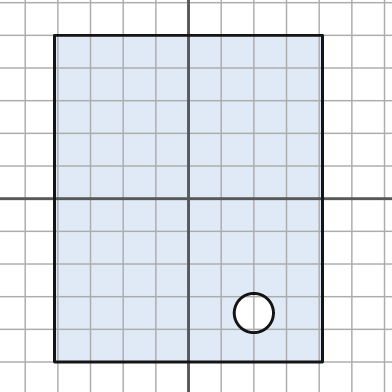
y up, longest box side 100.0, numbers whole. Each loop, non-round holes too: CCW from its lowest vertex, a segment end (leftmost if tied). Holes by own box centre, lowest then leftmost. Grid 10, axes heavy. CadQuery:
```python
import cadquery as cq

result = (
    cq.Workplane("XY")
    .moveTo(-41.0, -50.0)
    .lineTo(41.0, -50.0)
    .lineTo(41.0, 50.0)
    .lineTo(-41.0, 50.0)
    .close()
    .moveTo(20.0, -35.0)
    .circle(6.0)
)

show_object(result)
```